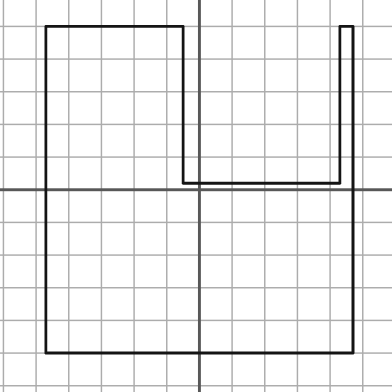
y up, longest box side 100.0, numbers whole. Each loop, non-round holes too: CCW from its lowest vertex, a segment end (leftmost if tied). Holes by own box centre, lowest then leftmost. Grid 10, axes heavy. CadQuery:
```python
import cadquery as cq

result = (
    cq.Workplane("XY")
    .moveTo(-47.0, -50.0)
    .lineTo(47.0, -50.0)
    .lineTo(47.0, 50.0)
    .lineTo(43.0, 50.0)
    .lineTo(43.0, 2.0)
    .lineTo(-5.0, 2.0)
    .lineTo(-5.0, 50.0)
    .lineTo(-47.0, 50.0)
    .close()
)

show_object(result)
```